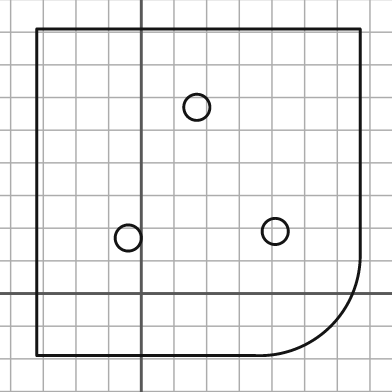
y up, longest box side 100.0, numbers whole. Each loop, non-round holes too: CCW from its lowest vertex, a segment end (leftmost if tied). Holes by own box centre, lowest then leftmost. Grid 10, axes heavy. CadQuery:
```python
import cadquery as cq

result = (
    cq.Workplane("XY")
    .moveTo(-32.0, -19.0)
    .lineTo(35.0, -19.0)
    .threePointArc((58.0, -10.0), (67.0, 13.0))
    .lineTo(67.0, 81.0)
    .lineTo(-32.0, 81.0)
    .close()
    .moveTo(-4.0, 17.0)
    .circle(4.0)
    .moveTo(41.0, 19.0)
    .circle(4.0)
    .moveTo(17.0, 57.0)
    .circle(4.0)
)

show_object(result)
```